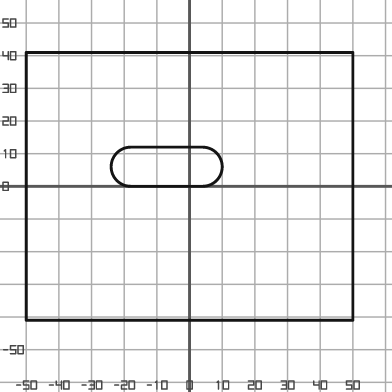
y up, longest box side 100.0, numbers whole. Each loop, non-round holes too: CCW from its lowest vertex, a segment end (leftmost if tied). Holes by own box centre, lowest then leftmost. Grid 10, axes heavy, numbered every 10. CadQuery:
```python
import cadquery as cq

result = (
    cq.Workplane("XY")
    .moveTo(-50.0, -41.0)
    .lineTo(50.0, -41.0)
    .lineTo(50.0, 41.0)
    .lineTo(-50.0, 41.0)
    .close()
    .moveTo(-18.0, 0.0)
    .lineTo(4.0, 0.0)
    .threePointArc((10.0, 6.0), (4.0, 12.0))
    .lineTo(-18.0, 12.0)
    .threePointArc((-24.0, 6.0), (-18.0, 0.0))
    .close()
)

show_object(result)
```